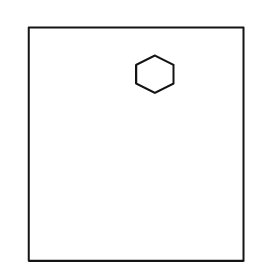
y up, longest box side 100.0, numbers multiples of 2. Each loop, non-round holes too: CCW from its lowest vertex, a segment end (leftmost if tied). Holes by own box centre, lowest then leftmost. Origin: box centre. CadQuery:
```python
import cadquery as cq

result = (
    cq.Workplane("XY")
    .moveTo(-46.0, -50.0)
    .lineTo(46.0, -50.0)
    .lineTo(46.0, 50.0)
    .lineTo(-46.0, 50.0)
    .close()
    .moveTo(8.0, 22.0)
    .lineTo(16.0, 26.0)
    .lineTo(16.0, 34.0)
    .lineTo(8.0, 38.0)
    .lineTo(0.0, 34.0)
    .lineTo(0.0, 26.0)
    .close()
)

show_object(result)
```